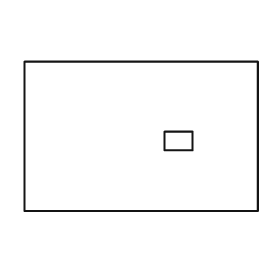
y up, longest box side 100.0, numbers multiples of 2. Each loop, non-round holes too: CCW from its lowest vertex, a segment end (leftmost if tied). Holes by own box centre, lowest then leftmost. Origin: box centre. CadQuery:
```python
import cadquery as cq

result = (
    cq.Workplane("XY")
    .moveTo(-50.0, -32.0)
    .lineTo(50.0, -32.0)
    .lineTo(50.0, 32.0)
    .lineTo(-50.0, 32.0)
    .close()
    .moveTo(10.0, -6.0)
    .lineTo(22.0, -6.0)
    .lineTo(22.0, 2.0)
    .lineTo(10.0, 2.0)
    .close()
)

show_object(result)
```